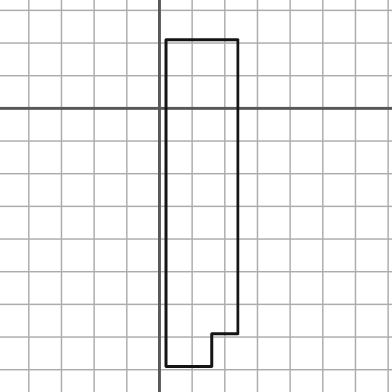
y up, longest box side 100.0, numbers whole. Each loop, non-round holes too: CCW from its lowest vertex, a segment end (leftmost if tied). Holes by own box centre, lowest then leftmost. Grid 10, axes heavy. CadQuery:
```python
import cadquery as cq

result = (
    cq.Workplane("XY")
    .moveTo(2.0, -79.0)
    .lineTo(16.0, -79.0)
    .lineTo(16.0, -69.0)
    .lineTo(24.0, -69.0)
    .lineTo(24.0, 21.0)
    .lineTo(2.0, 21.0)
    .close()
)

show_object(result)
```